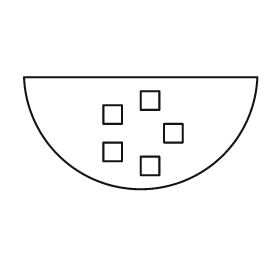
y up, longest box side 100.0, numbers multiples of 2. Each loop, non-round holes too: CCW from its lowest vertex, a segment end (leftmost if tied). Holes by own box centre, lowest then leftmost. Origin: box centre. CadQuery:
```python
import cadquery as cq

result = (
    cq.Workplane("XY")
    .moveTo(-50.0, 24.0)
    .threePointArc((0.0, -24.0), (50.0, 24.0))
    .close()
    .moveTo(0.0, -18.0)
    .lineTo(8.0, -18.0)
    .lineTo(8.0, -10.0)
    .lineTo(0.0, -10.0)
    .close()
    .moveTo(-16.0, -12.0)
    .lineTo(-8.0, -12.0)
    .lineTo(-8.0, -4.0)
    .lineTo(-16.0, -4.0)
    .close()
    .moveTo(10.0, -4.0)
    .lineTo(18.0, -4.0)
    .lineTo(18.0, 4.0)
    .lineTo(10.0, 4.0)
    .close()
    .moveTo(-16.0, 4.0)
    .lineTo(-8.0, 4.0)
    .lineTo(-8.0, 12.0)
    .lineTo(-16.0, 12.0)
    .close()
    .moveTo(0.0, 10.0)
    .lineTo(8.0, 10.0)
    .lineTo(8.0, 18.0)
    .lineTo(0.0, 18.0)
    .close()
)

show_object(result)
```